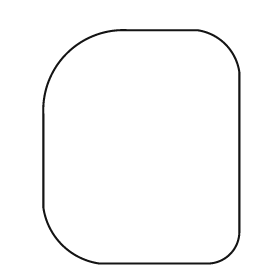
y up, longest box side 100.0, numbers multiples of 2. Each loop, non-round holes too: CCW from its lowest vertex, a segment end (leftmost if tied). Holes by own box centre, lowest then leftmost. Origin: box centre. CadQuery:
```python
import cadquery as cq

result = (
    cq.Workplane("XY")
    .moveTo(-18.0, -50.0)
    .lineTo(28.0, -50.0)
    .threePointArc((38.0, -46.0), (42.0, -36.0))
    .lineTo(42.0, 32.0)
    .threePointArc((36.0, 44.0), (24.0, 50.0))
    .lineTo(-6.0, 50.0)
    .threePointArc((-32.0, 40.0), (-42.0, 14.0))
    .lineTo(-42.0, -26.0)
    .threePointArc((-34.0, -42.0), (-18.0, -50.0))
    .close()
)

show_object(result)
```